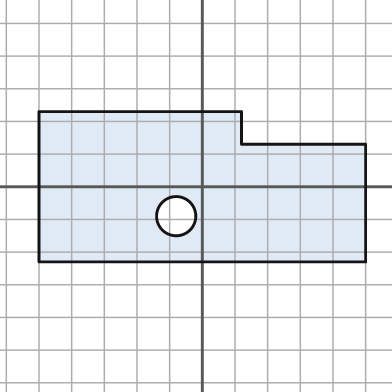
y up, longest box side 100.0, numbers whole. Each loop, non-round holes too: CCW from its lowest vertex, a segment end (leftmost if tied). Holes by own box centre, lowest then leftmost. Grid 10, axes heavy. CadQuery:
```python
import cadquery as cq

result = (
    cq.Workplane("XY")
    .moveTo(-50.0, -23.0)
    .lineTo(50.0, -23.0)
    .lineTo(50.0, 13.0)
    .lineTo(12.0, 13.0)
    .lineTo(12.0, 23.0)
    .lineTo(-50.0, 23.0)
    .close()
    .moveTo(-8.0, -9.0)
    .circle(6.0)
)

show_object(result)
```